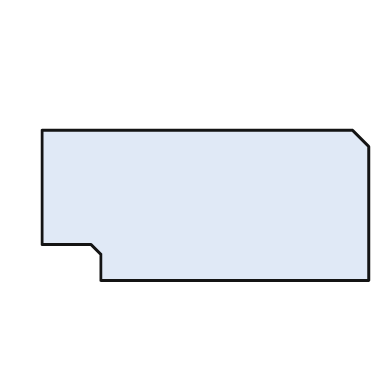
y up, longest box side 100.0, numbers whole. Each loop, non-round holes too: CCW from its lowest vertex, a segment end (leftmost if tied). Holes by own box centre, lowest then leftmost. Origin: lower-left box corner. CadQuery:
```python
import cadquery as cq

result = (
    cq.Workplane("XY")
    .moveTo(18.0, 0.0)
    .lineTo(100.0, 0.0)
    .lineTo(100.0, 41.0)
    .lineTo(95.0, 46.0)
    .lineTo(0.0, 46.0)
    .lineTo(0.0, 11.0)
    .lineTo(15.0, 11.0)
    .lineTo(18.0, 8.0)
    .close()
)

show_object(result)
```